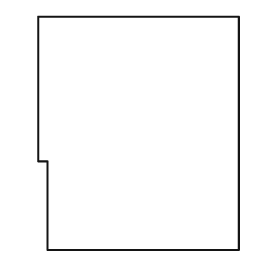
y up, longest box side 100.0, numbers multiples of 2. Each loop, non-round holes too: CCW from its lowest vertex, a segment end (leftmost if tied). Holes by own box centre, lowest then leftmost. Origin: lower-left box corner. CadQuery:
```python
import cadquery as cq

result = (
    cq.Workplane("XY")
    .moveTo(4.0, 0.0)
    .lineTo(86.0, 0.0)
    .lineTo(86.0, 100.0)
    .lineTo(0.0, 100.0)
    .lineTo(0.0, 38.0)
    .lineTo(4.0, 38.0)
    .close()
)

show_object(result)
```